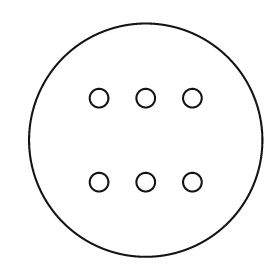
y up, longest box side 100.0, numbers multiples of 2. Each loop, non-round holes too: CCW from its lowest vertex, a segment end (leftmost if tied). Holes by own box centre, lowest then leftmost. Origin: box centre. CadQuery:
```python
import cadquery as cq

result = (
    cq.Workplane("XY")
    .moveTo(0.0, 0.0)
    .circle(50.0)
    .moveTo(-20.0, -18.0)
    .circle(4.0)
    .moveTo(0.0, -18.0)
    .circle(4.0)
    .moveTo(20.0, -18.0)
    .circle(4.0)
    .moveTo(-20.0, 18.0)
    .circle(4.0)
    .moveTo(0.0, 18.0)
    .circle(4.0)
    .moveTo(20.0, 18.0)
    .circle(4.0)
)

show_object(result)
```